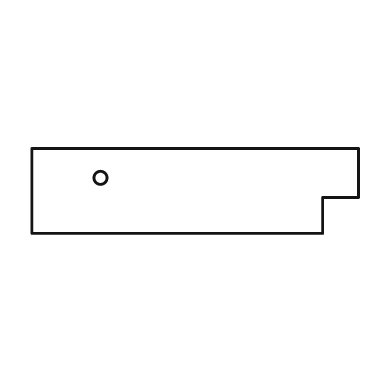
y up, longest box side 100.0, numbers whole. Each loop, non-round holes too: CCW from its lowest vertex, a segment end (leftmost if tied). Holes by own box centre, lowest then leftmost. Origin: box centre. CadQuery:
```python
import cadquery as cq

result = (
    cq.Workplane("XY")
    .moveTo(-50.0, -13.0)
    .lineTo(39.0, -13.0)
    .lineTo(39.0, -2.0)
    .lineTo(50.0, -2.0)
    .lineTo(50.0, 13.0)
    .lineTo(-50.0, 13.0)
    .close()
    .moveTo(-29.0, 4.0)
    .circle(2.0)
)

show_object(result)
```